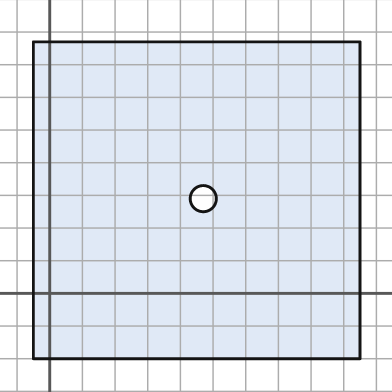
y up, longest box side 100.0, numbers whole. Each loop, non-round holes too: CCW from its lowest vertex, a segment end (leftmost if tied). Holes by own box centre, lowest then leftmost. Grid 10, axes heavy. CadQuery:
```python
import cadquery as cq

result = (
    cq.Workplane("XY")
    .moveTo(-5.0, -20.0)
    .lineTo(95.0, -20.0)
    .lineTo(95.0, 77.0)
    .lineTo(-5.0, 77.0)
    .close()
    .moveTo(47.0, 29.0)
    .circle(4.0)
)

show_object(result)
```